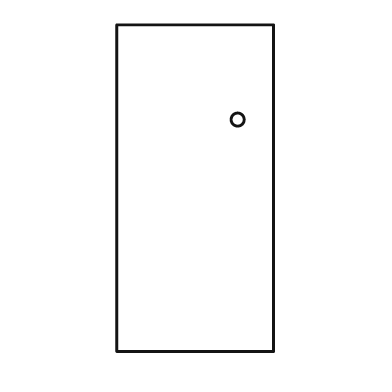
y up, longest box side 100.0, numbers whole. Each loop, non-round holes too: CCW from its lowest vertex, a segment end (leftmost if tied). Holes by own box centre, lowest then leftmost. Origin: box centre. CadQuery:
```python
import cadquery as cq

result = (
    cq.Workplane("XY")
    .moveTo(-24.0, -50.0)
    .lineTo(24.0, -50.0)
    .lineTo(24.0, 50.0)
    .lineTo(-24.0, 50.0)
    .close()
    .moveTo(13.0, 21.0)
    .circle(2.0)
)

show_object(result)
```